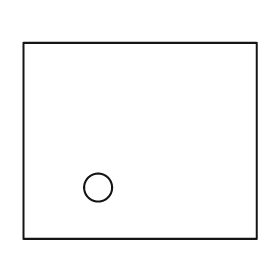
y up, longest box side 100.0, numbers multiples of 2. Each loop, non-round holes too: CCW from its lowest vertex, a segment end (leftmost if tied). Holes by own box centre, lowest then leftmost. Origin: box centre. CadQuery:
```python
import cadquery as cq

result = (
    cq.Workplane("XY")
    .moveTo(-50.0, -42.0)
    .lineTo(50.0, -42.0)
    .lineTo(50.0, 42.0)
    .lineTo(-50.0, 42.0)
    .close()
    .moveTo(-18.0, -20.0)
    .circle(6.0)
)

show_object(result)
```